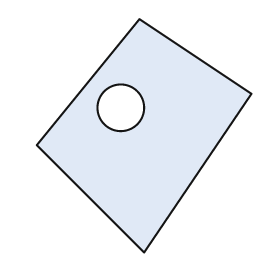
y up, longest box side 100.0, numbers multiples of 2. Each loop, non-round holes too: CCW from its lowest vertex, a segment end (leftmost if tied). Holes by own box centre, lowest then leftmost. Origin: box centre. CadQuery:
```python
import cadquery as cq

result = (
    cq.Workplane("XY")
    .moveTo(0.0, -50.0)
    .lineTo(46.0, 18.0)
    .lineTo(-2.0, 50.0)
    .lineTo(-46.0, -4.0)
    .close()
    .moveTo(-10.0, 12.0)
    .circle(10.0)
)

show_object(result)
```